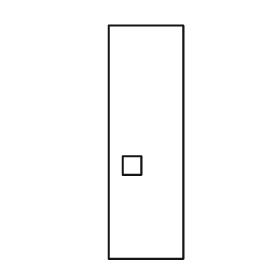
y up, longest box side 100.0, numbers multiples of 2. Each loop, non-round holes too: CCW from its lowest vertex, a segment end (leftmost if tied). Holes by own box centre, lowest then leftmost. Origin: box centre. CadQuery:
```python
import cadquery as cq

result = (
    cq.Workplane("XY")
    .moveTo(-16.0, -50.0)
    .lineTo(16.0, -50.0)
    .lineTo(16.0, 50.0)
    .lineTo(-16.0, 50.0)
    .close()
    .moveTo(-10.0, -14.0)
    .lineTo(-2.0, -14.0)
    .lineTo(-2.0, -6.0)
    .lineTo(-10.0, -6.0)
    .close()
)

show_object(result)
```